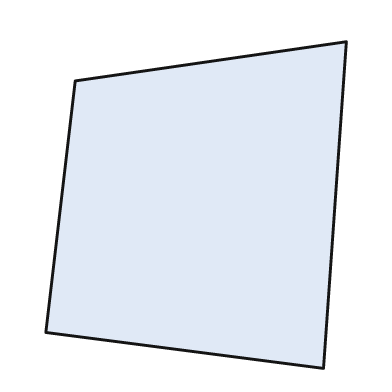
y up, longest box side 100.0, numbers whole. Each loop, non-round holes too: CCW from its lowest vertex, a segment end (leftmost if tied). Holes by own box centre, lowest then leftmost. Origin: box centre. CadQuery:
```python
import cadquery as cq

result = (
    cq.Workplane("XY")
    .moveTo(39.0, -50.0)
    .lineTo(46.0, 50.0)
    .lineTo(-37.0, 38.0)
    .lineTo(-46.0, -39.0)
    .close()
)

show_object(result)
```